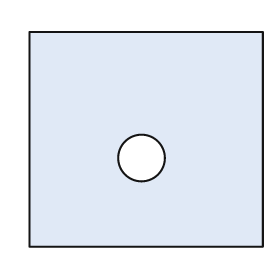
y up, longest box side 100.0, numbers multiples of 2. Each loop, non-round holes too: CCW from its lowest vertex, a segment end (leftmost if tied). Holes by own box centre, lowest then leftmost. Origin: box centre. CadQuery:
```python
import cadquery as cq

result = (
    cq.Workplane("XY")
    .moveTo(-50.0, -46.0)
    .lineTo(50.0, -46.0)
    .lineTo(50.0, 46.0)
    .lineTo(-50.0, 46.0)
    .close()
    .moveTo(-2.0, -8.0)
    .circle(10.0)
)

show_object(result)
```